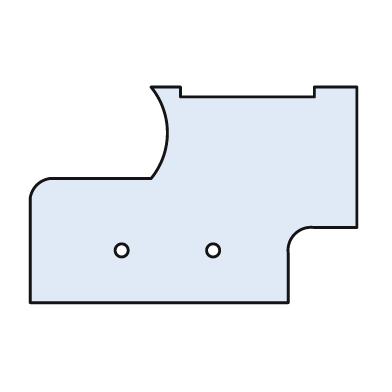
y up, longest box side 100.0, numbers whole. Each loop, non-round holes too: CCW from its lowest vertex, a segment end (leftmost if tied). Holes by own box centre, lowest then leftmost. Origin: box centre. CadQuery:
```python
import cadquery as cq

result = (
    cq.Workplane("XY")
    .moveTo(-50.0, -33.0)
    .lineTo(29.0, -33.0)
    .lineTo(29.0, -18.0)
    .threePointArc((31.0, -12.0), (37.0, -10.0))
    .lineTo(50.0, -10.0)
    .lineTo(50.0, 33.0)
    .lineTo(37.0, 33.0)
    .lineTo(37.0, 30.0)
    .lineTo(-4.0, 30.0)
    .lineTo(-4.0, 33.0)
    .lineTo(-13.0, 33.0)
    .threePointArc((-8.0, 19.0), (-13.0, 5.0))
    .lineTo(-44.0, 5.0)
    .threePointArc((-48.0, 3.0), (-50.0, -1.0))
    .close()
    .moveTo(-22.0, -17.0)
    .circle(2.0)
    .moveTo(6.0, -17.0)
    .circle(2.0)
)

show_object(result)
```